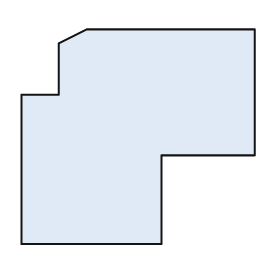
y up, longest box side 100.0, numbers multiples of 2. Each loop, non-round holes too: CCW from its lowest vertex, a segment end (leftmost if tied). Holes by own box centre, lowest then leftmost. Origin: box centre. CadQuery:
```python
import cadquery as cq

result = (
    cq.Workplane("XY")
    .moveTo(-50.0, -46.0)
    .lineTo(10.0, -46.0)
    .lineTo(10.0, -8.0)
    .lineTo(50.0, -8.0)
    .lineTo(50.0, 46.0)
    .lineTo(-22.0, 46.0)
    .lineTo(-34.0, 40.0)
    .lineTo(-34.0, 18.0)
    .lineTo(-50.0, 18.0)
    .close()
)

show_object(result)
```